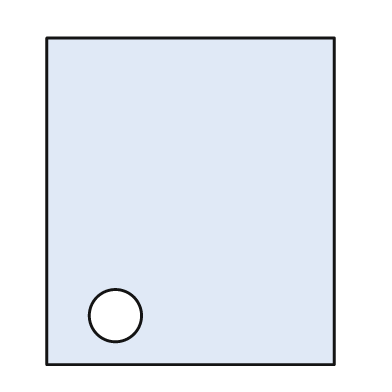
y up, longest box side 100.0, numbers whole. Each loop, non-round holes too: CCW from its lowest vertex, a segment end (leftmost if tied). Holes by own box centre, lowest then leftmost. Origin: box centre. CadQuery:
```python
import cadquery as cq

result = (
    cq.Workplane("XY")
    .moveTo(-44.0, -50.0)
    .lineTo(44.0, -50.0)
    .lineTo(44.0, 50.0)
    .lineTo(-44.0, 50.0)
    .close()
    .moveTo(-23.0, -35.0)
    .circle(8.0)
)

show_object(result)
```